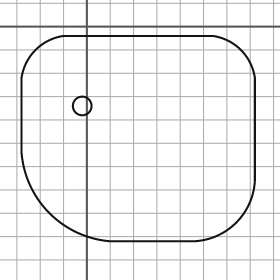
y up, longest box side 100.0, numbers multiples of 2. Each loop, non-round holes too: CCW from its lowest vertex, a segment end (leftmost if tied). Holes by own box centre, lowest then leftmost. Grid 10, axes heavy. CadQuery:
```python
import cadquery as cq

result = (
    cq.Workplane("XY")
    .moveTo(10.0, -92.0)
    .lineTo(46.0, -92.0)
    .threePointArc((64.0, -84.0), (72.0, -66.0))
    .lineTo(72.0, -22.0)
    .threePointArc((66.0, -10.0), (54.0, -4.0))
    .lineTo(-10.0, -4.0)
    .threePointArc((-22.0, -10.0), (-28.0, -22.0))
    .lineTo(-28.0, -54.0)
    .threePointArc((-16.0, -80.0), (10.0, -92.0))
    .close()
    .moveTo(-2.0, -34.0)
    .circle(4.0)
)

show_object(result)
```